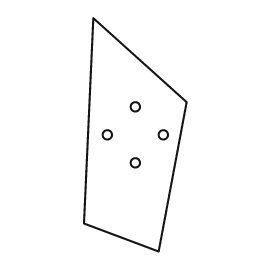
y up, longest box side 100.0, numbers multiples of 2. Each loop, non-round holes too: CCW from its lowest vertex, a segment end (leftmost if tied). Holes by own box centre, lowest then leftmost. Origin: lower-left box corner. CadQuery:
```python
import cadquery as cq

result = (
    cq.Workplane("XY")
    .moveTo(32.0, 0.0)
    .lineTo(44.0, 64.0)
    .lineTo(4.0, 100.0)
    .lineTo(0.0, 12.0)
    .close()
    .moveTo(22.0, 38.0)
    .circle(2.0)
    .moveTo(10.0, 50.0)
    .circle(2.0)
    .moveTo(34.0, 50.0)
    .circle(2.0)
    .moveTo(22.0, 62.0)
    .circle(2.0)
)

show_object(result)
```